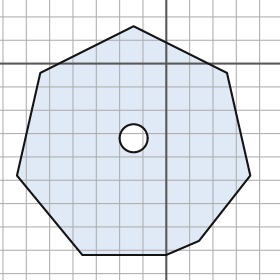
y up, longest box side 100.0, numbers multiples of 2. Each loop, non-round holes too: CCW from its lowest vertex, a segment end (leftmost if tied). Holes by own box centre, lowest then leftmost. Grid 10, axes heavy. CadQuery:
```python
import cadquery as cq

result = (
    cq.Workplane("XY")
    .moveTo(-36.0, -82.0)
    .lineTo(0.0, -82.0)
    .lineTo(14.0, -76.0)
    .lineTo(36.0, -48.0)
    .lineTo(26.0, -4.0)
    .lineTo(-14.0, 16.0)
    .lineTo(-54.0, -4.0)
    .lineTo(-64.0, -48.0)
    .close()
    .moveTo(-14.0, -32.0)
    .circle(6.0)
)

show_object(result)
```